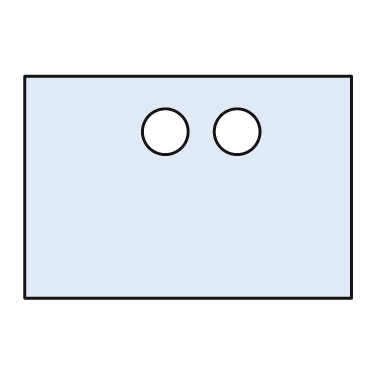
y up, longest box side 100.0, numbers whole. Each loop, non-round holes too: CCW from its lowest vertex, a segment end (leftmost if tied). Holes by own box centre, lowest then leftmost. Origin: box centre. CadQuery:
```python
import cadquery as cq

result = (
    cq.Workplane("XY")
    .moveTo(-50.0, -34.0)
    .lineTo(50.0, -34.0)
    .lineTo(50.0, 34.0)
    .lineTo(-50.0, 34.0)
    .close()
    .moveTo(-7.0, 17.0)
    .circle(7.0)
    .moveTo(15.0, 17.0)
    .circle(7.0)
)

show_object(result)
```